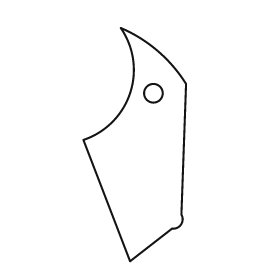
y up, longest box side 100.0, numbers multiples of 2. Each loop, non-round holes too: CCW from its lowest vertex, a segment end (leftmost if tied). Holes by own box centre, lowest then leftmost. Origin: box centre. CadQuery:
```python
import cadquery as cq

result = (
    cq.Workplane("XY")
    .moveTo(-2.0, -50.0)
    .lineTo(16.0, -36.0)
    .threePointArc((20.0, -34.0), (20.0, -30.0))
    .lineTo(22.0, 26.0)
    .threePointArc((10.0, 40.0), (-6.0, 50.0))
    .threePointArc((-2.0, 22.0), (-22.0, 2.0))
    .close()
    .moveTo(8.0, 22.0)
    .circle(4.0)
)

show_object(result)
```